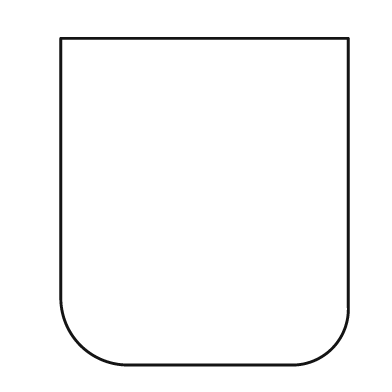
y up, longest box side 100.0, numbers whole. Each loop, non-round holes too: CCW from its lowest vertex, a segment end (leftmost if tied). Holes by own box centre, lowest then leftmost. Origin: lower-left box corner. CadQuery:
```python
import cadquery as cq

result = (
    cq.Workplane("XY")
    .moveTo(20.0, 0.0)
    .lineTo(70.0, 0.0)
    .threePointArc((83.0, 5.0), (88.0, 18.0))
    .lineTo(88.0, 100.0)
    .lineTo(0.0, 100.0)
    .lineTo(0.0, 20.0)
    .threePointArc((6.0, 6.0), (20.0, 0.0))
    .close()
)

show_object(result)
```